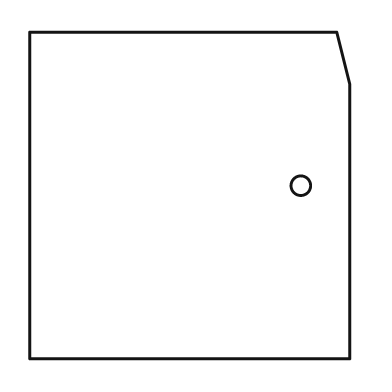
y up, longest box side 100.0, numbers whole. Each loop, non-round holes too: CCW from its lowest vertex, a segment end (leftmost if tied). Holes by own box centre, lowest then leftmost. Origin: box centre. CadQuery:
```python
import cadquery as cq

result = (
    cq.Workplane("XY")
    .moveTo(-49.0, -50.0)
    .lineTo(49.0, -50.0)
    .lineTo(49.0, 34.0)
    .lineTo(45.0, 50.0)
    .lineTo(-49.0, 50.0)
    .close()
    .moveTo(34.0, 3.0)
    .circle(3.0)
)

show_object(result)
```